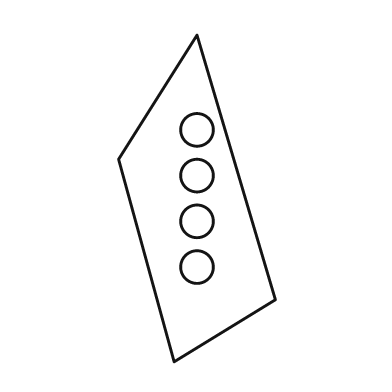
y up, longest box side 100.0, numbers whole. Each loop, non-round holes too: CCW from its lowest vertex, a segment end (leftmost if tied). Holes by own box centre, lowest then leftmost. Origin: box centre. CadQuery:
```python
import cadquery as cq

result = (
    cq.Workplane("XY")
    .moveTo(-7.0, -50.0)
    .lineTo(24.0, -31.0)
    .lineTo(0.0, 50.0)
    .lineTo(-24.0, 12.0)
    .close()
    .moveTo(0.0, -21.0)
    .circle(5.0)
    .moveTo(0.0, -7.0)
    .circle(5.0)
    .moveTo(0.0, 7.0)
    .circle(5.0)
    .moveTo(0.0, 21.0)
    .circle(5.0)
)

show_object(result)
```